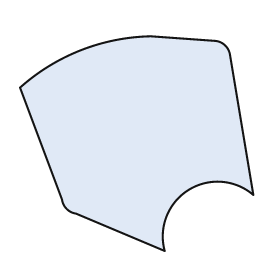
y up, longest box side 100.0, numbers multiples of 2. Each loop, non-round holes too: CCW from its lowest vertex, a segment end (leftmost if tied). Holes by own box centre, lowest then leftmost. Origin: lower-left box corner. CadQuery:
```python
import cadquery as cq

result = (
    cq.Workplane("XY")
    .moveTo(62.0, 0.0)
    .threePointArc((72.0, 26.0), (100.0, 24.0))
    .lineTo(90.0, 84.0)
    .threePointArc((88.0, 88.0), (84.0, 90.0))
    .lineTo(56.0, 92.0)
    .threePointArc((26.0, 86.0), (0.0, 70.0))
    .lineTo(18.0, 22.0)
    .threePointArc((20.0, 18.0), (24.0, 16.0))
    .close()
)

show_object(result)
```